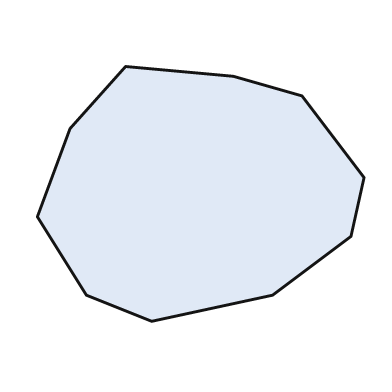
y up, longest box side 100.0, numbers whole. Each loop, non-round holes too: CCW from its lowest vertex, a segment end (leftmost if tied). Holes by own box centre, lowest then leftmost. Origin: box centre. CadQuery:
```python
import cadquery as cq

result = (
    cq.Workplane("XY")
    .moveTo(-15.0, -39.0)
    .lineTo(22.0, -31.0)
    .lineTo(46.0, -13.0)
    .lineTo(50.0, 5.0)
    .lineTo(31.0, 30.0)
    .lineTo(10.0, 36.0)
    .lineTo(-23.0, 39.0)
    .lineTo(-40.0, 20.0)
    .lineTo(-50.0, -7.0)
    .lineTo(-35.0, -31.0)
    .close()
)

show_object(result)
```